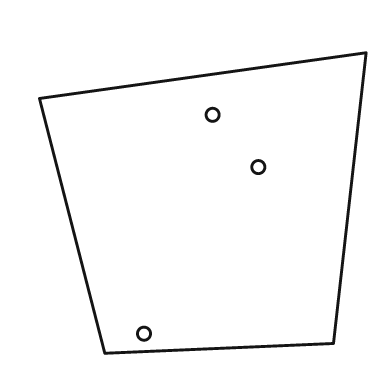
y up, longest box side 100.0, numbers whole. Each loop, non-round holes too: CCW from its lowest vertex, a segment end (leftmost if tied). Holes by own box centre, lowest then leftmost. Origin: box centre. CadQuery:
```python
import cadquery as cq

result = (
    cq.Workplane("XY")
    .moveTo(-30.0, -46.0)
    .lineTo(40.0, -43.0)
    .lineTo(50.0, 46.0)
    .lineTo(-50.0, 32.0)
    .close()
    .moveTo(-18.0, -40.0)
    .circle(2.0)
    .moveTo(17.0, 11.0)
    .circle(2.0)
    .moveTo(3.0, 27.0)
    .circle(2.0)
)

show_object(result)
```